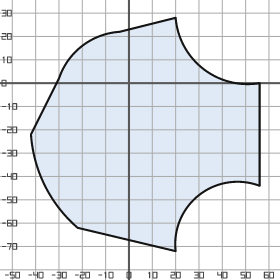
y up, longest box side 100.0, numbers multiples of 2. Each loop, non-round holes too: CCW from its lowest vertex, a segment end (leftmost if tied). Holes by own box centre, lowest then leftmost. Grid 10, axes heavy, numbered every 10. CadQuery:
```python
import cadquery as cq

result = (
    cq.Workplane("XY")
    .moveTo(20.0, -72.0)
    .threePointArc((30.0, -48.0), (56.0, -44.0))
    .lineTo(56.0, 0.0)
    .threePointArc((32.0, 6.0), (20.0, 28.0))
    .lineTo(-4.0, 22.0)
    .threePointArc((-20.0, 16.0), (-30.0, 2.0))
    .lineTo(-42.0, -22.0)
    .threePointArc((-36.0, -44.0), (-22.0, -62.0))
    .close()
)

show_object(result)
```